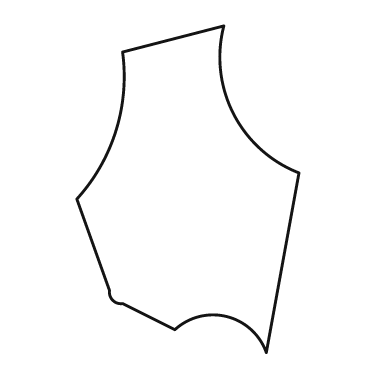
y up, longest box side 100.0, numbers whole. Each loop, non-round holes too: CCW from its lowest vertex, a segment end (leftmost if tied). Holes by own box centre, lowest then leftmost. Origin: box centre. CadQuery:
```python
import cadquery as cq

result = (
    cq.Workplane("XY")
    .moveTo(24.0, -50.0)
    .lineTo(34.0, 5.0)
    .threePointArc((14.0, 23.0), (11.0, 50.0))
    .lineTo(-20.0, 42.0)
    .threePointArc((-22.0, 18.0), (-34.0, -3.0))
    .lineTo(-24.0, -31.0)
    .threePointArc((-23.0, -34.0), (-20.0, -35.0))
    .lineTo(-4.0, -43.0)
    .threePointArc((12.0, -39.0), (24.0, -50.0))
    .close()
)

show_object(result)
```